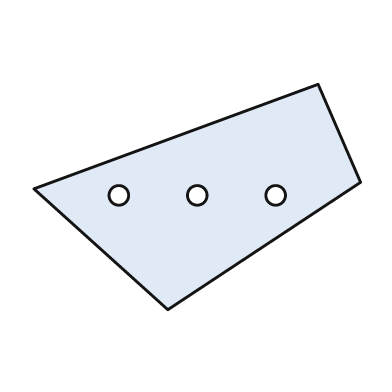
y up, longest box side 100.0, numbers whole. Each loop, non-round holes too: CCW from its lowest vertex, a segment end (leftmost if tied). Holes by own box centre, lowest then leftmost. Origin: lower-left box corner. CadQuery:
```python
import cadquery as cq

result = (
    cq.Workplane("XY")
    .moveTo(41.0, 0.0)
    .lineTo(100.0, 39.0)
    .lineTo(87.0, 69.0)
    .lineTo(0.0, 37.0)
    .close()
    .moveTo(26.0, 35.0)
    .circle(3.0)
    .moveTo(50.0, 35.0)
    .circle(3.0)
    .moveTo(74.0, 35.0)
    .circle(3.0)
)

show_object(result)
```